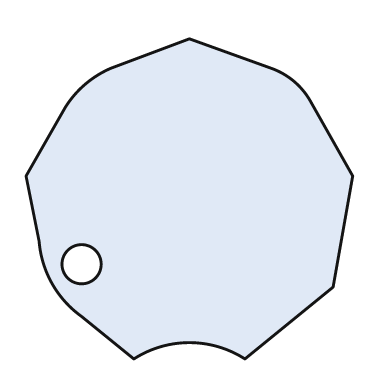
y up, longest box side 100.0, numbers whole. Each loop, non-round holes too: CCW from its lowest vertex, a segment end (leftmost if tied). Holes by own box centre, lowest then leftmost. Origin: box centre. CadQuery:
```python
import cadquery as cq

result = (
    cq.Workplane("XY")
    .moveTo(-17.0, -49.0)
    .threePointArc((0.0, -44.0), (17.0, -49.0))
    .lineTo(44.0, -27.0)
    .lineTo(50.0, 7.0)
    .lineTo(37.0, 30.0)
    .threePointArc((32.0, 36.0), (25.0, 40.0))
    .lineTo(0.0, 49.0)
    .lineTo(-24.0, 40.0)
    .threePointArc((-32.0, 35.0), (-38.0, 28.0))
    .lineTo(-50.0, 7.0)
    .lineTo(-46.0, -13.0)
    .threePointArc((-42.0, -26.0), (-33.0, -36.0))
    .close()
    .moveTo(-33.0, -20.0)
    .circle(6.0)
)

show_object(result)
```